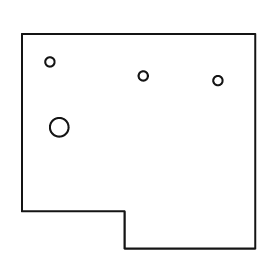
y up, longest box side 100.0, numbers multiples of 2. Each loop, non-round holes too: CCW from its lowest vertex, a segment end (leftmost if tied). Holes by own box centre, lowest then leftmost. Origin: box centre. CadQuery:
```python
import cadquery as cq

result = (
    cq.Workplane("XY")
    .moveTo(-6.0, -46.0)
    .lineTo(50.0, -46.0)
    .lineTo(50.0, 46.0)
    .lineTo(-50.0, 46.0)
    .lineTo(-50.0, -30.0)
    .lineTo(-6.0, -30.0)
    .close()
    .moveTo(-34.0, 6.0)
    .circle(4.0)
    .moveTo(34.0, 26.0)
    .circle(2.0)
    .moveTo(2.0, 28.0)
    .circle(2.0)
    .moveTo(-38.0, 34.0)
    .circle(2.0)
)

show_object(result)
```